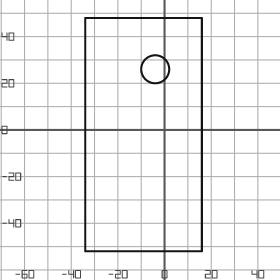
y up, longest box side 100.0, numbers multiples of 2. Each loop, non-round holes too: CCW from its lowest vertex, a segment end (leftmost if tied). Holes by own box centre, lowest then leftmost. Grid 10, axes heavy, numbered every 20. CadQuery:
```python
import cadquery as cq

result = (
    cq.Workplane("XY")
    .moveTo(-34.0, -52.0)
    .lineTo(16.0, -52.0)
    .lineTo(16.0, 48.0)
    .lineTo(-34.0, 48.0)
    .close()
    .moveTo(-4.0, 26.0)
    .circle(6.0)
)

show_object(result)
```